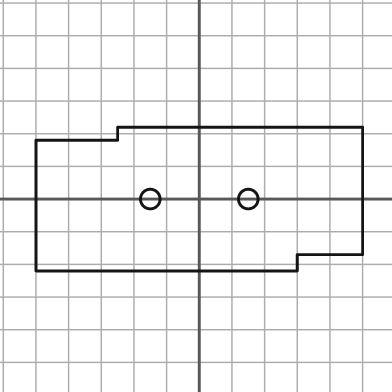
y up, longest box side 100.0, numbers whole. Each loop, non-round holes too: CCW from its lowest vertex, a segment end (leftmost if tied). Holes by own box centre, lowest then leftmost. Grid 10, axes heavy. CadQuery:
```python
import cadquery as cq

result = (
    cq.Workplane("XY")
    .moveTo(-50.0, -22.0)
    .lineTo(30.0, -22.0)
    .lineTo(30.0, -17.0)
    .lineTo(50.0, -17.0)
    .lineTo(50.0, 22.0)
    .lineTo(-25.0, 22.0)
    .lineTo(-25.0, 18.0)
    .lineTo(-50.0, 18.0)
    .close()
    .moveTo(-15.0, 0.0)
    .circle(3.0)
    .moveTo(15.0, 0.0)
    .circle(3.0)
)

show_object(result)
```